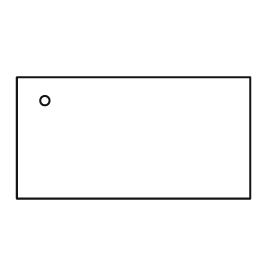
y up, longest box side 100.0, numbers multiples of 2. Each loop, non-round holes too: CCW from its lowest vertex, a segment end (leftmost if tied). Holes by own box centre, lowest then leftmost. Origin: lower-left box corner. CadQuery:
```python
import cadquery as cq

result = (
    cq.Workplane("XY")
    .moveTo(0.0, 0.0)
    .lineTo(100.0, 0.0)
    .lineTo(100.0, 52.0)
    .lineTo(0.0, 52.0)
    .close()
    .moveTo(12.0, 42.0)
    .circle(2.0)
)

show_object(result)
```